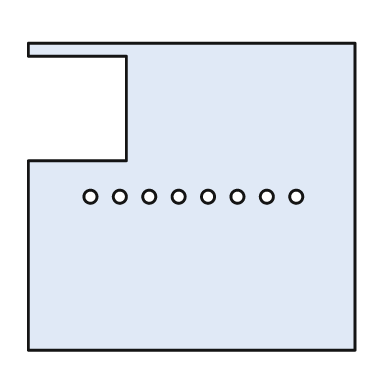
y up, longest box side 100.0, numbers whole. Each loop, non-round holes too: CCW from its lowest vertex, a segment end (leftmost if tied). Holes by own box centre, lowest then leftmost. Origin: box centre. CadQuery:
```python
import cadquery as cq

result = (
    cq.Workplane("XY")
    .moveTo(-50.0, -47.0)
    .lineTo(50.0, -47.0)
    .lineTo(50.0, 47.0)
    .lineTo(-50.0, 47.0)
    .lineTo(-50.0, 43.0)
    .lineTo(-20.0, 43.0)
    .lineTo(-20.0, 11.0)
    .lineTo(-50.0, 11.0)
    .close()
    .moveTo(-31.0, 0.0)
    .circle(2.0)
    .moveTo(-22.0, 0.0)
    .circle(2.0)
    .moveTo(-13.0, 0.0)
    .circle(2.0)
    .moveTo(-4.0, 0.0)
    .circle(2.0)
    .moveTo(5.0, 0.0)
    .circle(2.0)
    .moveTo(14.0, 0.0)
    .circle(2.0)
    .moveTo(23.0, 0.0)
    .circle(2.0)
    .moveTo(32.0, 0.0)
    .circle(2.0)
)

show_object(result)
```